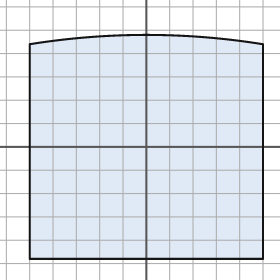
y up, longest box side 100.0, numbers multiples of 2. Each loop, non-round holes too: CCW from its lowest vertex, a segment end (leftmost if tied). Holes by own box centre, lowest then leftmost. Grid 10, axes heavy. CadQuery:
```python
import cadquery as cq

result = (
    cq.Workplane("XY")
    .moveTo(-50.0, -48.0)
    .lineTo(50.0, -48.0)
    .lineTo(50.0, 44.0)
    .threePointArc((0.0, 48.0), (-50.0, 44.0))
    .close()
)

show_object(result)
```